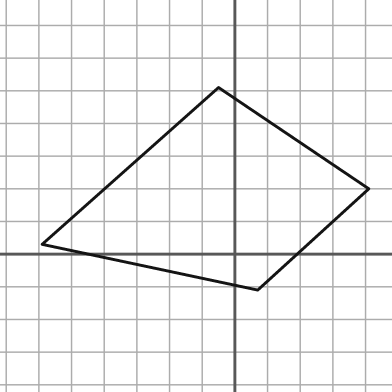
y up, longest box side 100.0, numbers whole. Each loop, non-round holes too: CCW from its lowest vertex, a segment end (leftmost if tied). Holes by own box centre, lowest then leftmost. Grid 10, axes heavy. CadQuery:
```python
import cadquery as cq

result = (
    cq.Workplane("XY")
    .moveTo(7.0, -11.0)
    .lineTo(41.0, 20.0)
    .lineTo(-5.0, 51.0)
    .lineTo(-59.0, 3.0)
    .close()
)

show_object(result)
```